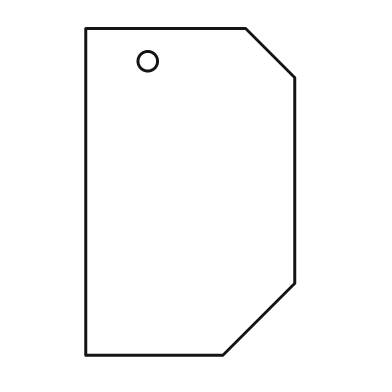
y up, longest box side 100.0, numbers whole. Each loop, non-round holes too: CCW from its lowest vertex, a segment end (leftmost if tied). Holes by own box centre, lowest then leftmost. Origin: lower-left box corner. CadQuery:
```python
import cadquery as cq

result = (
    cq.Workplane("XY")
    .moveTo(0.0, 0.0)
    .lineTo(42.0, 0.0)
    .lineTo(64.0, 22.0)
    .lineTo(64.0, 85.0)
    .lineTo(49.0, 100.0)
    .lineTo(0.0, 100.0)
    .close()
    .moveTo(19.0, 90.0)
    .circle(3.0)
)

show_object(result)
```